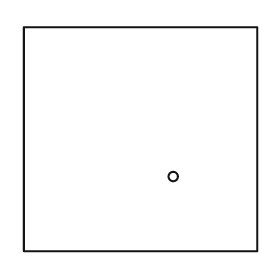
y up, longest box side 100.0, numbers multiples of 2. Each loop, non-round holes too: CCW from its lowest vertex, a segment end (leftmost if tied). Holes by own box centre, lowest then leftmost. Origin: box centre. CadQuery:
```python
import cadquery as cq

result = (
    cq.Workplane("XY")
    .moveTo(-50.0, -48.0)
    .lineTo(50.0, -48.0)
    .lineTo(50.0, 48.0)
    .lineTo(-50.0, 48.0)
    .close()
    .moveTo(14.0, -16.0)
    .circle(2.0)
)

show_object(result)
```